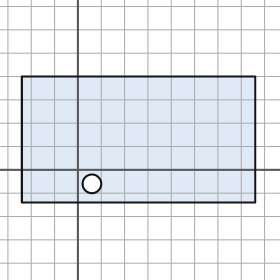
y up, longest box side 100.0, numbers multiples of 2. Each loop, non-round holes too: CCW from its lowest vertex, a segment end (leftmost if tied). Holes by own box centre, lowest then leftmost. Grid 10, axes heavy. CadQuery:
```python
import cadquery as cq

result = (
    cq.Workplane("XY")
    .moveTo(-24.0, -14.0)
    .lineTo(76.0, -14.0)
    .lineTo(76.0, 40.0)
    .lineTo(-24.0, 40.0)
    .close()
    .moveTo(6.0, -6.0)
    .circle(4.0)
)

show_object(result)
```